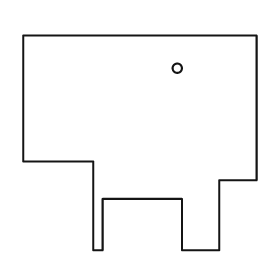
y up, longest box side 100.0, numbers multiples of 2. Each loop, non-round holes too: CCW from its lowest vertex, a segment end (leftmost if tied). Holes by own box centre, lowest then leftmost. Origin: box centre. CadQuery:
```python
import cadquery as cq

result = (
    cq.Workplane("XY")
    .moveTo(-20.0, -46.0)
    .lineTo(-16.0, -46.0)
    .lineTo(-16.0, -24.0)
    .lineTo(18.0, -24.0)
    .lineTo(18.0, -46.0)
    .lineTo(34.0, -46.0)
    .lineTo(34.0, -16.0)
    .lineTo(50.0, -16.0)
    .lineTo(50.0, 46.0)
    .lineTo(-50.0, 46.0)
    .lineTo(-50.0, -8.0)
    .lineTo(-20.0, -8.0)
    .close()
    .moveTo(16.0, 32.0)
    .circle(2.0)
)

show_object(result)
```